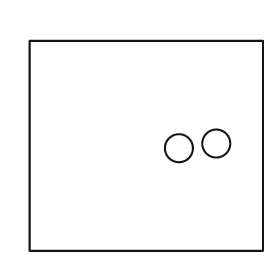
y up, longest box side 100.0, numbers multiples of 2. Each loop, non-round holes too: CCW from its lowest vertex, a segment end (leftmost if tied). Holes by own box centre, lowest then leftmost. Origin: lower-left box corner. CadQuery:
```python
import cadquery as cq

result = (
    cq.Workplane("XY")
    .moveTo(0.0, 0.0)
    .lineTo(100.0, 0.0)
    .lineTo(100.0, 90.0)
    .lineTo(0.0, 90.0)
    .close()
    .moveTo(64.0, 44.0)
    .circle(6.0)
    .moveTo(80.0, 46.0)
    .circle(6.0)
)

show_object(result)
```